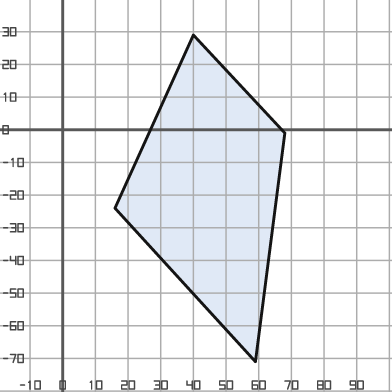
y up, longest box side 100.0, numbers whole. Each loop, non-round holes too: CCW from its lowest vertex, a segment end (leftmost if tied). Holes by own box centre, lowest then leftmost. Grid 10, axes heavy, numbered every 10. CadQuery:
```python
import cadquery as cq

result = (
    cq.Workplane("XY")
    .moveTo(59.0, -71.0)
    .lineTo(68.0, -1.0)
    .lineTo(40.0, 29.0)
    .lineTo(16.0, -24.0)
    .close()
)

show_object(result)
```